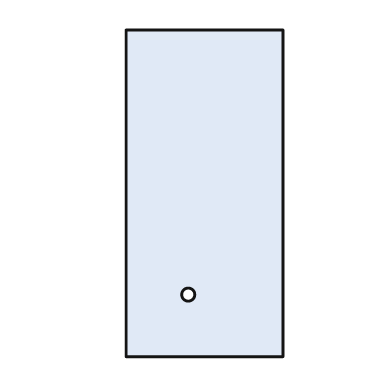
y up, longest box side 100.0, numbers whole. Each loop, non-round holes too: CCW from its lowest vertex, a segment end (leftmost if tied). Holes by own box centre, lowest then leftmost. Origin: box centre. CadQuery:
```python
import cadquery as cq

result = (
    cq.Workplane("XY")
    .moveTo(-24.0, -50.0)
    .lineTo(24.0, -50.0)
    .lineTo(24.0, 50.0)
    .lineTo(-24.0, 50.0)
    .close()
    .moveTo(-5.0, -31.0)
    .circle(2.0)
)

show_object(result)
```